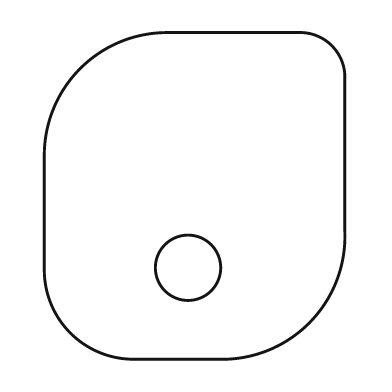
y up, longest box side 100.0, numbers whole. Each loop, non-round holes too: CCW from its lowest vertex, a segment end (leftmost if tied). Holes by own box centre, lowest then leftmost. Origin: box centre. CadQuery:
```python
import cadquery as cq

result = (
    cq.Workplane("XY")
    .moveTo(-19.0, -50.0)
    .lineTo(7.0, -50.0)
    .threePointArc((35.0, -39.0), (46.0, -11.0))
    .lineTo(46.0, 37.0)
    .threePointArc((42.0, 46.0), (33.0, 50.0))
    .lineTo(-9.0, 50.0)
    .threePointArc((-35.0, 39.0), (-46.0, 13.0))
    .lineTo(-46.0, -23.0)
    .threePointArc((-38.0, -42.0), (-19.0, -50.0))
    .close()
    .moveTo(-2.0, -22.0)
    .circle(10.0)
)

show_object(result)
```